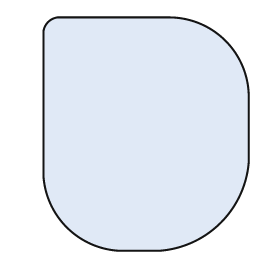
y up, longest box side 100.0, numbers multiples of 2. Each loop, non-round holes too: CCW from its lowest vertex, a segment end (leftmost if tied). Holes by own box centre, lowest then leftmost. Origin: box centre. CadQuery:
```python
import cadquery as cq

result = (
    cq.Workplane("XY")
    .moveTo(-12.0, -50.0)
    .lineTo(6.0, -50.0)
    .threePointArc((32.0, -38.0), (44.0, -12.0))
    .lineTo(44.0, 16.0)
    .threePointArc((34.0, 40.0), (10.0, 50.0))
    .lineTo(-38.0, 50.0)
    .threePointArc((-42.0, 48.0), (-44.0, 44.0))
    .lineTo(-44.0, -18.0)
    .threePointArc((-34.0, -40.0), (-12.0, -50.0))
    .close()
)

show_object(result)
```